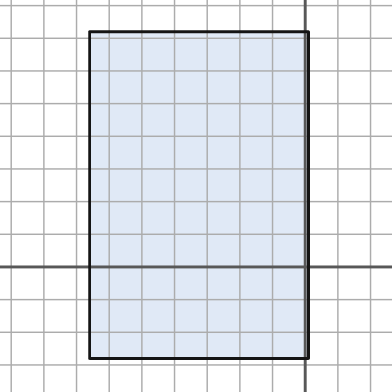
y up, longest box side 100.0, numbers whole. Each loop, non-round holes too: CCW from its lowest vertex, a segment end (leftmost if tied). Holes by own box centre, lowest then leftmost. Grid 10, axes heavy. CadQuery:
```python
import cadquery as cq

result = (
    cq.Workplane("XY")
    .moveTo(-66.0, -28.0)
    .lineTo(1.0, -28.0)
    .lineTo(1.0, 72.0)
    .lineTo(-66.0, 72.0)
    .close()
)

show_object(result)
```